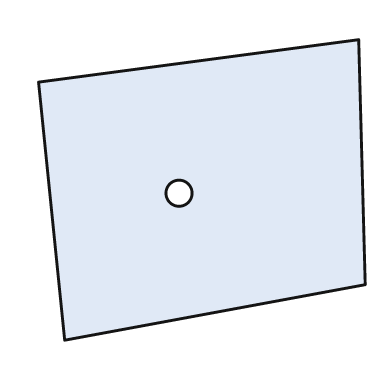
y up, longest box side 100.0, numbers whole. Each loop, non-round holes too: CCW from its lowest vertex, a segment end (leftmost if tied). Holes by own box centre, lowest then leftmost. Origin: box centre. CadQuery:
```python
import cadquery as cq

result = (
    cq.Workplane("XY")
    .moveTo(-42.0, -46.0)
    .lineTo(50.0, -29.0)
    .lineTo(48.0, 46.0)
    .lineTo(-50.0, 33.0)
    .close()
    .moveTo(-7.0, -1.0)
    .circle(4.0)
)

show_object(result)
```